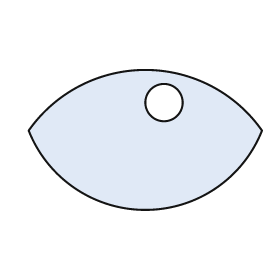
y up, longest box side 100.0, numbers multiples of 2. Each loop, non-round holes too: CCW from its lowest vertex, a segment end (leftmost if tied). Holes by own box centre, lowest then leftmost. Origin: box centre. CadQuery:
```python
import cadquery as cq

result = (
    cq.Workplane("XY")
    .moveTo(-50.0, 4.0)
    .threePointArc((0.0, -30.0), (50.0, 4.0))
    .threePointArc((0.0, 30.0), (-50.0, 4.0))
    .close()
    .moveTo(8.0, 16.0)
    .circle(8.0)
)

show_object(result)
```